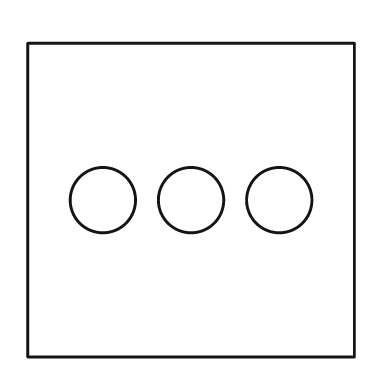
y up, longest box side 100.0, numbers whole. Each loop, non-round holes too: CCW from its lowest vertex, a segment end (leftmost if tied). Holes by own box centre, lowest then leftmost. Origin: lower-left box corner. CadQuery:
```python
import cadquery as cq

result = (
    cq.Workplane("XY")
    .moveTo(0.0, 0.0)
    .lineTo(100.0, 0.0)
    .lineTo(100.0, 96.0)
    .lineTo(0.0, 96.0)
    .close()
    .moveTo(23.0, 48.0)
    .circle(10.0)
    .moveTo(50.0, 48.0)
    .circle(10.0)
    .moveTo(77.0, 48.0)
    .circle(10.0)
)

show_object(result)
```